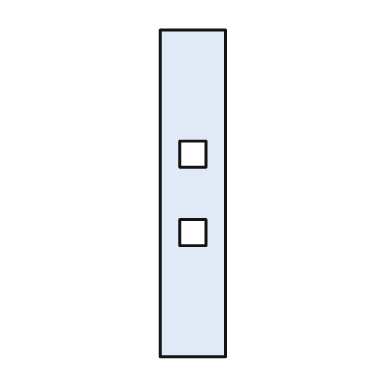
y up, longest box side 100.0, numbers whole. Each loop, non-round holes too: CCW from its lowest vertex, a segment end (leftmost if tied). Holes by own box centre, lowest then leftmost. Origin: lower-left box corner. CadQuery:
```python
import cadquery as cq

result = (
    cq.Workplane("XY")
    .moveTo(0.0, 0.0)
    .lineTo(20.0, 0.0)
    .lineTo(20.0, 100.0)
    .lineTo(0.0, 100.0)
    .close()
    .moveTo(6.0, 34.0)
    .lineTo(14.0, 34.0)
    .lineTo(14.0, 42.0)
    .lineTo(6.0, 42.0)
    .close()
    .moveTo(6.0, 58.0)
    .lineTo(14.0, 58.0)
    .lineTo(14.0, 66.0)
    .lineTo(6.0, 66.0)
    .close()
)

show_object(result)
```